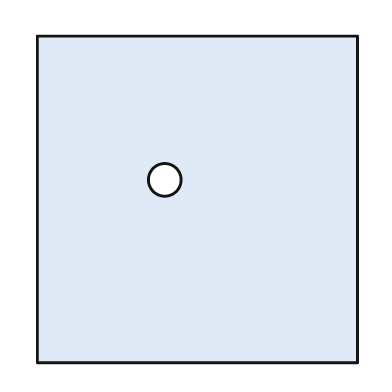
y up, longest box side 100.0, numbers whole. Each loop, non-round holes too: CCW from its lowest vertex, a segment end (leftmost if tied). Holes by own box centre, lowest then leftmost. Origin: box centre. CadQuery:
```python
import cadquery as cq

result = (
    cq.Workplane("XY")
    .moveTo(-49.0, -50.0)
    .lineTo(49.0, -50.0)
    .lineTo(49.0, 50.0)
    .lineTo(-49.0, 50.0)
    .close()
    .moveTo(-10.0, 6.0)
    .circle(5.0)
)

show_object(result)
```